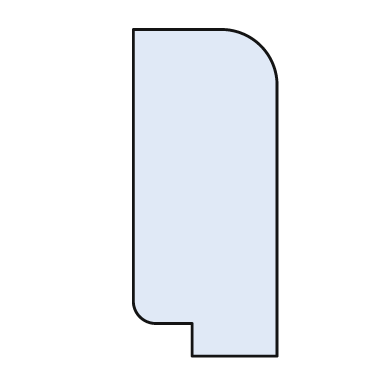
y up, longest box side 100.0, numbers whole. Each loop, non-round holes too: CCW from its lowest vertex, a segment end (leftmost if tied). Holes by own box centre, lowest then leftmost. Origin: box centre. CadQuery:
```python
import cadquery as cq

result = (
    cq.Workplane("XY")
    .moveTo(-4.0, -50.0)
    .lineTo(22.0, -50.0)
    .lineTo(22.0, 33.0)
    .threePointArc((17.0, 45.0), (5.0, 50.0))
    .lineTo(-22.0, 50.0)
    .lineTo(-22.0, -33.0)
    .threePointArc((-20.0, -38.0), (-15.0, -40.0))
    .lineTo(-4.0, -40.0)
    .close()
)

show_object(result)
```